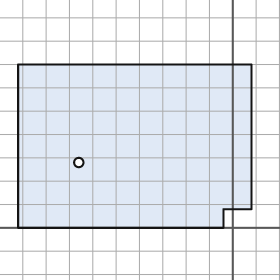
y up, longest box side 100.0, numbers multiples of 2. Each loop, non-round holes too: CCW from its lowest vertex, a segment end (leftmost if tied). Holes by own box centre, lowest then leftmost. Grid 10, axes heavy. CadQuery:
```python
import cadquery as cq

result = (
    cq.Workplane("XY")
    .moveTo(-92.0, 0.0)
    .lineTo(-4.0, 0.0)
    .lineTo(-4.0, 8.0)
    .lineTo(8.0, 8.0)
    .lineTo(8.0, 70.0)
    .lineTo(-92.0, 70.0)
    .close()
    .moveTo(-66.0, 28.0)
    .circle(2.0)
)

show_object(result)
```